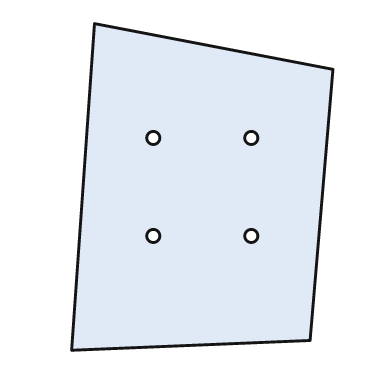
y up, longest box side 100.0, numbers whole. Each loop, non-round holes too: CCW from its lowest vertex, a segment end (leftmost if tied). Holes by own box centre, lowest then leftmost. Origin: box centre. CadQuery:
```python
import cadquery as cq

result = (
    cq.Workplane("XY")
    .moveTo(-40.0, -50.0)
    .lineTo(33.0, -47.0)
    .lineTo(40.0, 36.0)
    .lineTo(-33.0, 50.0)
    .close()
    .moveTo(-15.0, -15.0)
    .circle(2.0)
    .moveTo(15.0, -15.0)
    .circle(2.0)
    .moveTo(-15.0, 15.0)
    .circle(2.0)
    .moveTo(15.0, 15.0)
    .circle(2.0)
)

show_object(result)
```